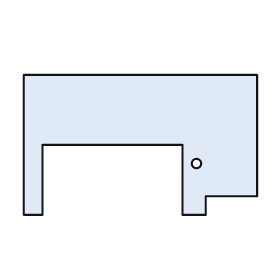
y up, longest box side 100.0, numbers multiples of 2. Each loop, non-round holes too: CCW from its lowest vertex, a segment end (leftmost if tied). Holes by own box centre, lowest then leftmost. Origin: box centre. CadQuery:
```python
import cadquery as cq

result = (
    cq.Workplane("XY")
    .moveTo(-50.0, -30.0)
    .lineTo(-42.0, -30.0)
    .lineTo(-42.0, 0.0)
    .lineTo(18.0, 0.0)
    .lineTo(18.0, -30.0)
    .lineTo(28.0, -30.0)
    .lineTo(28.0, -22.0)
    .lineTo(50.0, -22.0)
    .lineTo(50.0, 30.0)
    .lineTo(-50.0, 30.0)
    .close()
    .moveTo(24.0, -8.0)
    .circle(2.0)
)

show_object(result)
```